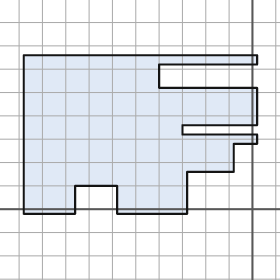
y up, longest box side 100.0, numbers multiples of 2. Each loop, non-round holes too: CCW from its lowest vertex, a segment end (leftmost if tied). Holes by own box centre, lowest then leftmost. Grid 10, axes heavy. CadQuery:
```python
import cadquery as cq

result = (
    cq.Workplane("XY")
    .moveTo(-98.0, -2.0)
    .lineTo(-76.0, -2.0)
    .lineTo(-76.0, 10.0)
    .lineTo(-58.0, 10.0)
    .lineTo(-58.0, -2.0)
    .lineTo(-28.0, -2.0)
    .lineTo(-28.0, 16.0)
    .lineTo(-8.0, 16.0)
    .lineTo(-8.0, 28.0)
    .lineTo(2.0, 28.0)
    .lineTo(2.0, 32.0)
    .lineTo(-30.0, 32.0)
    .lineTo(-30.0, 36.0)
    .lineTo(2.0, 36.0)
    .lineTo(2.0, 52.0)
    .lineTo(-40.0, 52.0)
    .lineTo(-40.0, 62.0)
    .lineTo(2.0, 62.0)
    .lineTo(2.0, 66.0)
    .lineTo(-98.0, 66.0)
    .close()
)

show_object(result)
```